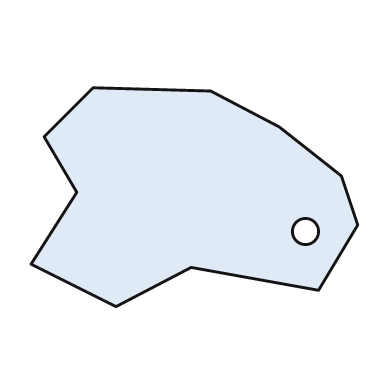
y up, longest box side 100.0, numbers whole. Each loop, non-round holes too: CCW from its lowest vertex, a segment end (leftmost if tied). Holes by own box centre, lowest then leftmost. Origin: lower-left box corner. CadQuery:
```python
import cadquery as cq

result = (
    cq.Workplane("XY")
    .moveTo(26.0, 0.0)
    .lineTo(49.0, 12.0)
    .lineTo(88.0, 5.0)
    .lineTo(100.0, 25.0)
    .lineTo(95.0, 40.0)
    .lineTo(76.0, 55.0)
    .lineTo(55.0, 66.0)
    .lineTo(19.0, 67.0)
    .lineTo(4.0, 52.0)
    .lineTo(14.0, 35.0)
    .lineTo(0.0, 13.0)
    .close()
    .moveTo(84.0, 23.0)
    .circle(4.0)
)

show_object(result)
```